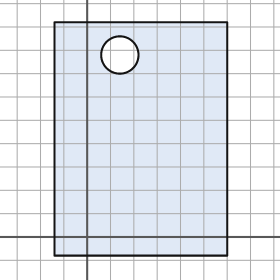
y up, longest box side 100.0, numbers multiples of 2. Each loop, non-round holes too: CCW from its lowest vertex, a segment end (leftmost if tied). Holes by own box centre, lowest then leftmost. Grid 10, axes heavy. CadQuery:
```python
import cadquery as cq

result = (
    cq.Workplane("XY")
    .moveTo(-14.0, -8.0)
    .lineTo(60.0, -8.0)
    .lineTo(60.0, 92.0)
    .lineTo(-14.0, 92.0)
    .close()
    .moveTo(14.0, 78.0)
    .circle(8.0)
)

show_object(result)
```